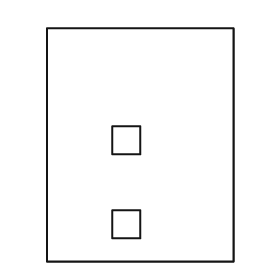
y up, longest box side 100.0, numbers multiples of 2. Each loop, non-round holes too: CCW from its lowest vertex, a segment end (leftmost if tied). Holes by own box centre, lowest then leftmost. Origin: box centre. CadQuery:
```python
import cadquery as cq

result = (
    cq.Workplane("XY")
    .moveTo(-40.0, -50.0)
    .lineTo(40.0, -50.0)
    .lineTo(40.0, 50.0)
    .lineTo(-40.0, 50.0)
    .close()
    .moveTo(-12.0, -40.0)
    .lineTo(0.0, -40.0)
    .lineTo(0.0, -28.0)
    .lineTo(-12.0, -28.0)
    .close()
    .moveTo(-12.0, -4.0)
    .lineTo(0.0, -4.0)
    .lineTo(0.0, 8.0)
    .lineTo(-12.0, 8.0)
    .close()
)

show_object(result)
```